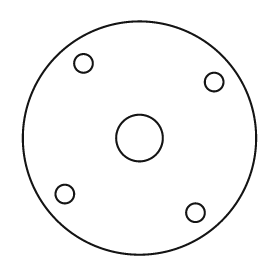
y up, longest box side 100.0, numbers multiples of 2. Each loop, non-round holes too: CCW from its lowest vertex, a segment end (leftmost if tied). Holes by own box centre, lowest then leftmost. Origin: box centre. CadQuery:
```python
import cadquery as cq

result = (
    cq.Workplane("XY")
    .moveTo(0.0, 0.0)
    .circle(50.0)
    .moveTo(24.0, -32.0)
    .circle(4.0)
    .moveTo(-32.0, -24.0)
    .circle(4.0)
    .moveTo(0.0, 0.0)
    .circle(10.0)
    .moveTo(32.0, 24.0)
    .circle(4.0)
    .moveTo(-24.0, 32.0)
    .circle(4.0)
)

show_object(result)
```